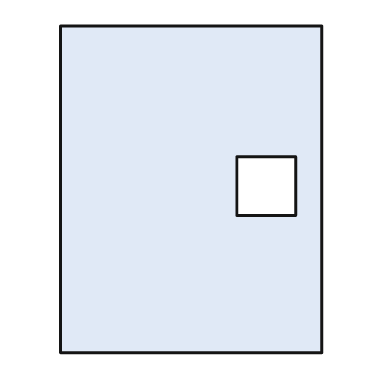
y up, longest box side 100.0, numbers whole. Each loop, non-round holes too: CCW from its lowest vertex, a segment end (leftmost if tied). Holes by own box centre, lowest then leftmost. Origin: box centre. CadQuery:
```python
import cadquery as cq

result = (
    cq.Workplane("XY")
    .moveTo(-40.0, -50.0)
    .lineTo(40.0, -50.0)
    .lineTo(40.0, 50.0)
    .lineTo(-40.0, 50.0)
    .close()
    .moveTo(14.0, -8.0)
    .lineTo(32.0, -8.0)
    .lineTo(32.0, 10.0)
    .lineTo(14.0, 10.0)
    .close()
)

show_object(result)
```